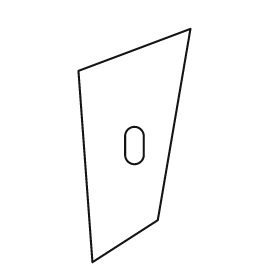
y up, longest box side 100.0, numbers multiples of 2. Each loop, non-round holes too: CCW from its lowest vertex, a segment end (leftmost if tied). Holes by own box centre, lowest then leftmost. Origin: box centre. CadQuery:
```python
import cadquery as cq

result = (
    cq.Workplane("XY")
    .moveTo(-18.0, -50.0)
    .lineTo(10.0, -32.0)
    .lineTo(24.0, 50.0)
    .lineTo(-24.0, 32.0)
    .close()
    .moveTo(-4.0, -4.0)
    .threePointArc((0.0, -8.0), (4.0, -4.0))
    .lineTo(4.0, 4.0)
    .threePointArc((0.0, 8.0), (-4.0, 4.0))
    .close()
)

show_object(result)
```